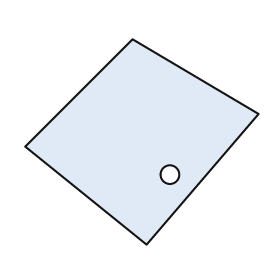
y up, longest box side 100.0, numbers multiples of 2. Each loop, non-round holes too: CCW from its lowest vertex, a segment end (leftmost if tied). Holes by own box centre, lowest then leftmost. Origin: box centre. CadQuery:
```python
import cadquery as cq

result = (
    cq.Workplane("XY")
    .moveTo(2.0, -44.0)
    .lineTo(50.0, 12.0)
    .lineTo(-4.0, 44.0)
    .lineTo(-50.0, -2.0)
    .close()
    .moveTo(12.0, -14.0)
    .circle(4.0)
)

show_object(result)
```